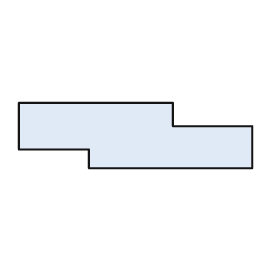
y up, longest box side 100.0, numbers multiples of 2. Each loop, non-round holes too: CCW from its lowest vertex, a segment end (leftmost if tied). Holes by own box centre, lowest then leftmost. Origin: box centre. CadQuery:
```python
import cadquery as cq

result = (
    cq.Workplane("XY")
    .moveTo(-20.0, -14.0)
    .lineTo(50.0, -14.0)
    .lineTo(50.0, 4.0)
    .lineTo(16.0, 4.0)
    .lineTo(16.0, 14.0)
    .lineTo(-50.0, 14.0)
    .lineTo(-50.0, -6.0)
    .lineTo(-20.0, -6.0)
    .close()
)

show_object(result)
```